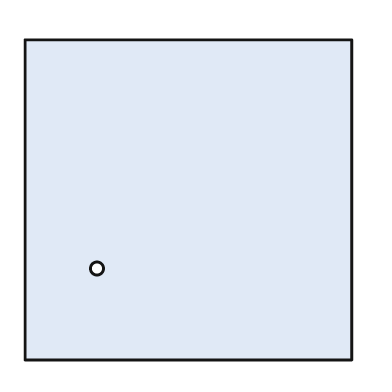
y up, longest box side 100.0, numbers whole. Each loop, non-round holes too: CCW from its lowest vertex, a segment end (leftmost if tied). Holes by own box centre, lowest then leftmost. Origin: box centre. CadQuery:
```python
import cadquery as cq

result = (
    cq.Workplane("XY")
    .moveTo(-50.0, -49.0)
    .lineTo(50.0, -49.0)
    .lineTo(50.0, 49.0)
    .lineTo(-50.0, 49.0)
    .close()
    .moveTo(-28.0, -21.0)
    .circle(2.0)
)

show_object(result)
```